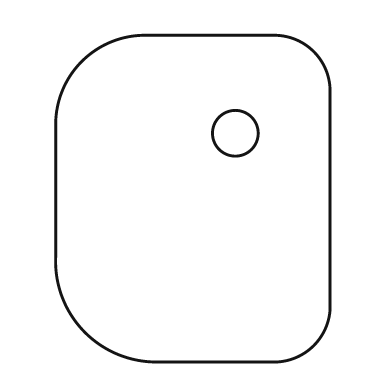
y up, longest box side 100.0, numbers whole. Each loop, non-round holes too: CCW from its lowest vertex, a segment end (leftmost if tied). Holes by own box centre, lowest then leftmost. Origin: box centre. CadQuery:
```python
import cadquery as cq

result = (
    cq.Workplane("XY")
    .moveTo(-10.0, -50.0)
    .lineTo(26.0, -50.0)
    .threePointArc((37.0, -45.0), (42.0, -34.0))
    .lineTo(42.0, 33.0)
    .threePointArc((37.0, 45.0), (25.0, 50.0))
    .lineTo(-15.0, 50.0)
    .threePointArc((-34.0, 42.0), (-42.0, 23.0))
    .lineTo(-42.0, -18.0)
    .threePointArc((-33.0, -41.0), (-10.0, -50.0))
    .close()
    .moveTo(13.0, 20.0)
    .circle(7.0)
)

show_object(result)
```